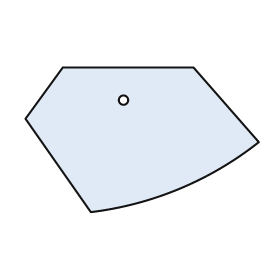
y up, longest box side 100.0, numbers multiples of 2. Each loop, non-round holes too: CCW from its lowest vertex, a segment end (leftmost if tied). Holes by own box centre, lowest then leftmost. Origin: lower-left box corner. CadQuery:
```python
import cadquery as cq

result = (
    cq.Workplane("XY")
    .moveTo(28.0, 0.0)
    .threePointArc((66.0, 10.0), (100.0, 30.0))
    .lineTo(72.0, 62.0)
    .lineTo(16.0, 62.0)
    .lineTo(0.0, 40.0)
    .close()
    .moveTo(42.0, 48.0)
    .circle(2.0)
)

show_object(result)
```